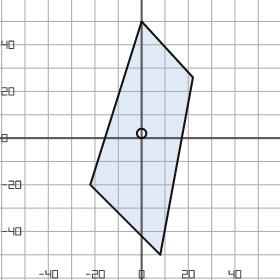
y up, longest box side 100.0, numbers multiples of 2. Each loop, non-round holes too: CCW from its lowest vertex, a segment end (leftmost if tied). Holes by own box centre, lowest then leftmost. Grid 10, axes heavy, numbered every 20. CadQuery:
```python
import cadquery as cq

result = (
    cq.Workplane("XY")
    .moveTo(8.0, -50.0)
    .lineTo(22.0, 26.0)
    .lineTo(0.0, 50.0)
    .lineTo(-22.0, -20.0)
    .close()
    .moveTo(0.0, 2.0)
    .circle(2.0)
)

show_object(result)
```